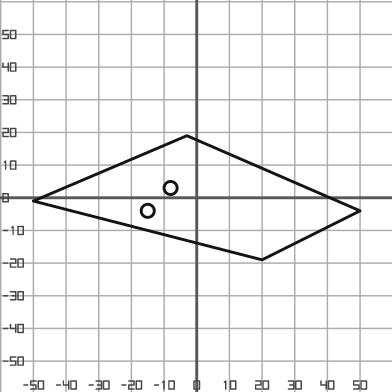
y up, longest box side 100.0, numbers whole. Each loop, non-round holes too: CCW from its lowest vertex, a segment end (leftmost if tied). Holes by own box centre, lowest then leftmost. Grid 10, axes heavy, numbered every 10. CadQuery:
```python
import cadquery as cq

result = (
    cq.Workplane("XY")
    .moveTo(20.0, -19.0)
    .lineTo(50.0, -4.0)
    .lineTo(-3.0, 19.0)
    .lineTo(-50.0, -1.0)
    .close()
    .moveTo(-15.0, -4.0)
    .circle(2.0)
    .moveTo(-8.0, 3.0)
    .circle(2.0)
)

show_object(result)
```